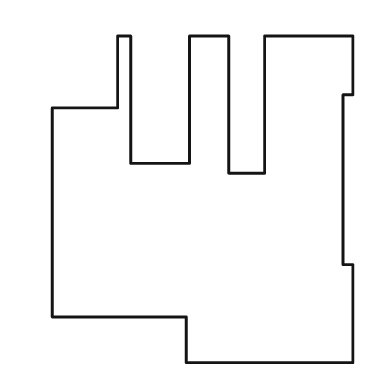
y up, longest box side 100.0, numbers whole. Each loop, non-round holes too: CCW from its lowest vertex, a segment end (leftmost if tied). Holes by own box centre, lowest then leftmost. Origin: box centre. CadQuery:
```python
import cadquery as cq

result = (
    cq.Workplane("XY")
    .moveTo(-5.0, -50.0)
    .lineTo(46.0, -50.0)
    .lineTo(46.0, -20.0)
    .lineTo(43.0, -20.0)
    .lineTo(43.0, 32.0)
    .lineTo(46.0, 32.0)
    .lineTo(46.0, 50.0)
    .lineTo(19.0, 50.0)
    .lineTo(19.0, 8.0)
    .lineTo(8.0, 8.0)
    .lineTo(8.0, 50.0)
    .lineTo(-4.0, 50.0)
    .lineTo(-4.0, 11.0)
    .lineTo(-22.0, 11.0)
    .lineTo(-22.0, 50.0)
    .lineTo(-26.0, 50.0)
    .lineTo(-26.0, 28.0)
    .lineTo(-46.0, 28.0)
    .lineTo(-46.0, -36.0)
    .lineTo(-5.0, -36.0)
    .close()
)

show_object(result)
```